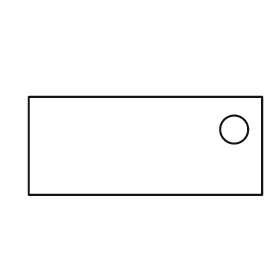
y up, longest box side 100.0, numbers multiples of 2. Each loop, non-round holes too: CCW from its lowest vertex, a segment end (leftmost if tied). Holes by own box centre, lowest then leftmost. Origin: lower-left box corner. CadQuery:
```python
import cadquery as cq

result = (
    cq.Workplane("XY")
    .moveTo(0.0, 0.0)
    .lineTo(100.0, 0.0)
    .lineTo(100.0, 42.0)
    .lineTo(0.0, 42.0)
    .close()
    .moveTo(88.0, 28.0)
    .circle(6.0)
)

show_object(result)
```